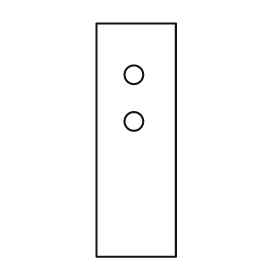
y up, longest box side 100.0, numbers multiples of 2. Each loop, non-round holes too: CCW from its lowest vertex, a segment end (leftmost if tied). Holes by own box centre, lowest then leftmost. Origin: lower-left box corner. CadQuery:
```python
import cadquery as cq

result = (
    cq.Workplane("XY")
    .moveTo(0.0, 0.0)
    .lineTo(34.0, 0.0)
    .lineTo(34.0, 100.0)
    .lineTo(0.0, 100.0)
    .close()
    .moveTo(16.0, 58.0)
    .circle(4.0)
    .moveTo(16.0, 78.0)
    .circle(4.0)
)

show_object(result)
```